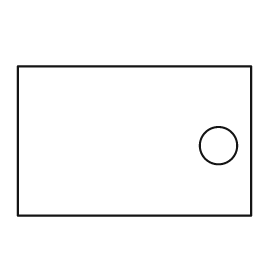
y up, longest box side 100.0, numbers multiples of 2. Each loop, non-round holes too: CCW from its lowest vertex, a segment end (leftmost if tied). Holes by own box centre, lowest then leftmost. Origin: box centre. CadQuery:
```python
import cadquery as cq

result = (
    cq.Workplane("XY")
    .moveTo(-50.0, -32.0)
    .lineTo(50.0, -32.0)
    .lineTo(50.0, 32.0)
    .lineTo(-50.0, 32.0)
    .close()
    .moveTo(36.0, -2.0)
    .circle(8.0)
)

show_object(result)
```